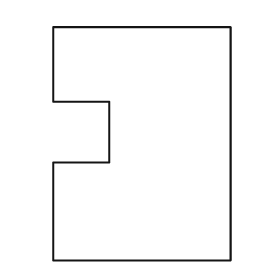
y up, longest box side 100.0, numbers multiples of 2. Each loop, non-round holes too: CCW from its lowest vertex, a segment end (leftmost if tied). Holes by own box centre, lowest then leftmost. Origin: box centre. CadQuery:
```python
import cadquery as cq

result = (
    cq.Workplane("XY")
    .moveTo(-38.0, -50.0)
    .lineTo(38.0, -50.0)
    .lineTo(38.0, 50.0)
    .lineTo(-38.0, 50.0)
    .lineTo(-38.0, 18.0)
    .lineTo(-14.0, 18.0)
    .lineTo(-14.0, -8.0)
    .lineTo(-38.0, -8.0)
    .close()
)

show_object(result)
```